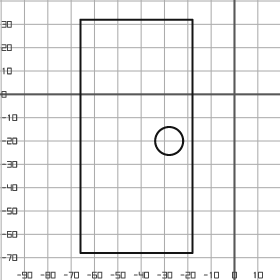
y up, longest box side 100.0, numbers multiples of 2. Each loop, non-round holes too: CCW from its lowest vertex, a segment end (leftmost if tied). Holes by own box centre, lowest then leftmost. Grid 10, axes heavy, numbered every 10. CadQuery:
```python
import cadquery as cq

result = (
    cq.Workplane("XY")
    .moveTo(-66.0, -68.0)
    .lineTo(-18.0, -68.0)
    .lineTo(-18.0, 32.0)
    .lineTo(-66.0, 32.0)
    .close()
    .moveTo(-28.0, -20.0)
    .circle(6.0)
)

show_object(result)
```